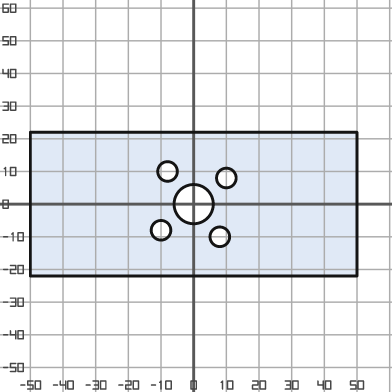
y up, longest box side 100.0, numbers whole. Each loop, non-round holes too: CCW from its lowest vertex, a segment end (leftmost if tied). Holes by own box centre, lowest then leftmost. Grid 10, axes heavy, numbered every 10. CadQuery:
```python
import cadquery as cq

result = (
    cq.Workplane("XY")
    .moveTo(-50.0, -22.0)
    .lineTo(50.0, -22.0)
    .lineTo(50.0, 22.0)
    .lineTo(-50.0, 22.0)
    .close()
    .moveTo(8.0, -10.0)
    .circle(3.0)
    .moveTo(-10.0, -8.0)
    .circle(3.0)
    .moveTo(0.0, 0.0)
    .circle(6.0)
    .moveTo(10.0, 8.0)
    .circle(3.0)
    .moveTo(-8.0, 10.0)
    .circle(3.0)
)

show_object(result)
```